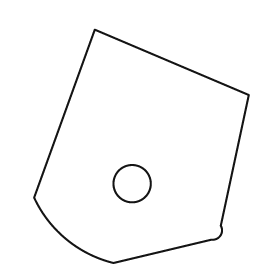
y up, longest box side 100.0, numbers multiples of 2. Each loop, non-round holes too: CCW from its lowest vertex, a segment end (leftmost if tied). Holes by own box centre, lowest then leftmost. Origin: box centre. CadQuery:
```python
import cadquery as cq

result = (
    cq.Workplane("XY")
    .moveTo(-12.0, -50.0)
    .lineTo(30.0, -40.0)
    .threePointArc((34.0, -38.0), (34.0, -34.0))
    .lineTo(46.0, 22.0)
    .lineTo(-20.0, 50.0)
    .lineTo(-46.0, -22.0)
    .threePointArc((-32.0, -40.0), (-12.0, -50.0))
    .close()
    .moveTo(-4.0, -16.0)
    .circle(8.0)
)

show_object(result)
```